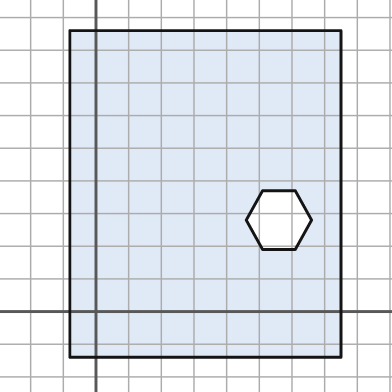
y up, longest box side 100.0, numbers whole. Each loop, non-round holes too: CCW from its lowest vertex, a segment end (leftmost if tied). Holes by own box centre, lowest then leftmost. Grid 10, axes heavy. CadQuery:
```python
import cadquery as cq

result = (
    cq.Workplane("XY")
    .moveTo(-8.0, -14.0)
    .lineTo(75.0, -14.0)
    .lineTo(75.0, 86.0)
    .lineTo(-8.0, 86.0)
    .close()
    .moveTo(51.0, 19.0)
    .lineTo(61.0, 19.0)
    .lineTo(66.0, 28.0)
    .lineTo(61.0, 37.0)
    .lineTo(51.0, 37.0)
    .lineTo(46.0, 28.0)
    .close()
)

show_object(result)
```